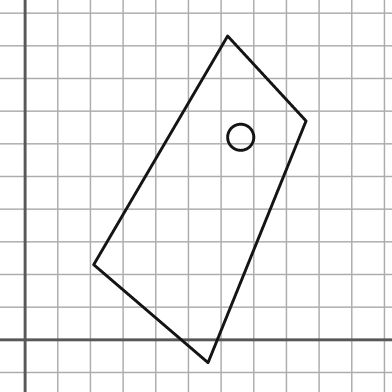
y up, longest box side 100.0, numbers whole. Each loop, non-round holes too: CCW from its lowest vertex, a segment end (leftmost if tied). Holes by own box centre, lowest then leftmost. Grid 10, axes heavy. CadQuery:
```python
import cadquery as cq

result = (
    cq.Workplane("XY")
    .moveTo(56.0, -7.0)
    .lineTo(86.0, 67.0)
    .lineTo(62.0, 93.0)
    .lineTo(21.0, 23.0)
    .close()
    .moveTo(66.0, 62.0)
    .circle(4.0)
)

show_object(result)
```